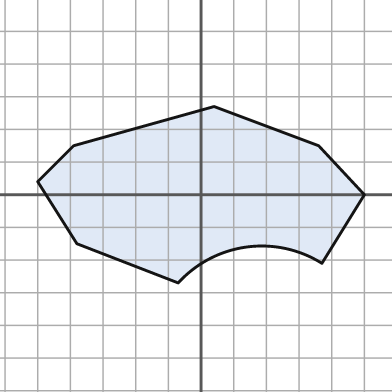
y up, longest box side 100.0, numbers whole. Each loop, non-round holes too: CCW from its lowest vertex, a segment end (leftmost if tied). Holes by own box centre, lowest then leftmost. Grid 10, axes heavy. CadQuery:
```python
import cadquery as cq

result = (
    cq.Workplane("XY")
    .moveTo(-7.0, -27.0)
    .threePointArc((14.0, -16.0), (37.0, -21.0))
    .lineTo(50.0, 0.0)
    .lineTo(36.0, 15.0)
    .lineTo(4.0, 27.0)
    .lineTo(-39.0, 15.0)
    .lineTo(-50.0, 4.0)
    .lineTo(-38.0, -15.0)
    .close()
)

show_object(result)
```